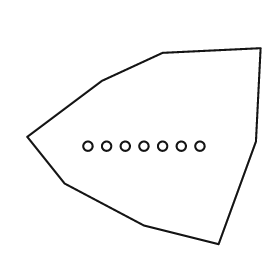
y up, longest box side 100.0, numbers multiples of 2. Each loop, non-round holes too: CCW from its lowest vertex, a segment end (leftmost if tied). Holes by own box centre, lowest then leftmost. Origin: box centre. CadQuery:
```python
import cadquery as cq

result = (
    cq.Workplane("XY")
    .moveTo(32.0, -42.0)
    .lineTo(48.0, 2.0)
    .lineTo(50.0, 42.0)
    .lineTo(8.0, 40.0)
    .lineTo(-18.0, 28.0)
    .lineTo(-50.0, 4.0)
    .lineTo(-34.0, -16.0)
    .lineTo(0.0, -34.0)
    .close()
    .moveTo(-24.0, 0.0)
    .circle(2.0)
    .moveTo(-16.0, 0.0)
    .circle(2.0)
    .moveTo(-8.0, 0.0)
    .circle(2.0)
    .moveTo(0.0, 0.0)
    .circle(2.0)
    .moveTo(8.0, 0.0)
    .circle(2.0)
    .moveTo(16.0, 0.0)
    .circle(2.0)
    .moveTo(24.0, 0.0)
    .circle(2.0)
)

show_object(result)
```